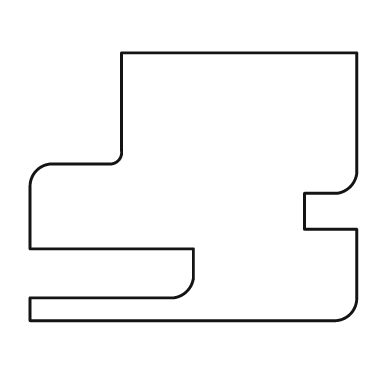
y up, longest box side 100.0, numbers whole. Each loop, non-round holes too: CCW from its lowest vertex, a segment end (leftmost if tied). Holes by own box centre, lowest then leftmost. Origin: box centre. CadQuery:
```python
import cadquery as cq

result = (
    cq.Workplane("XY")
    .moveTo(-50.0, -41.0)
    .lineTo(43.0, -41.0)
    .threePointArc((48.0, -39.0), (50.0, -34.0))
    .lineTo(50.0, -13.0)
    .lineTo(34.0, -13.0)
    .lineTo(34.0, -2.0)
    .lineTo(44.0, -2.0)
    .threePointArc((48.0, 0.0), (50.0, 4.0))
    .lineTo(50.0, 41.0)
    .lineTo(-22.0, 41.0)
    .lineTo(-22.0, 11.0)
    .threePointArc((-23.0, 8.0), (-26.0, 7.0))
    .lineTo(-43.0, 7.0)
    .threePointArc((-48.0, 5.0), (-50.0, 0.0))
    .lineTo(-50.0, -19.0)
    .lineTo(0.0, -19.0)
    .lineTo(0.0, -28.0)
    .threePointArc((-2.0, -32.0), (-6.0, -34.0))
    .lineTo(-50.0, -34.0)
    .close()
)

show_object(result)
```